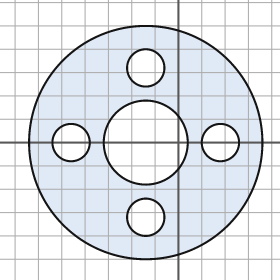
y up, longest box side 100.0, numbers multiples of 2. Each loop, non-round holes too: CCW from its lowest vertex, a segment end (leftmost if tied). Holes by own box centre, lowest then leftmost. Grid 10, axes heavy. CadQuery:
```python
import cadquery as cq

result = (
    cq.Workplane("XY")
    .moveTo(-14.0, 0.0)
    .circle(50.0)
    .moveTo(-14.0, -32.0)
    .circle(8.0)
    .moveTo(-46.0, 0.0)
    .circle(8.0)
    .moveTo(-14.0, 0.0)
    .circle(18.0)
    .moveTo(18.0, 0.0)
    .circle(8.0)
    .moveTo(-14.0, 32.0)
    .circle(8.0)
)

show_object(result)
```